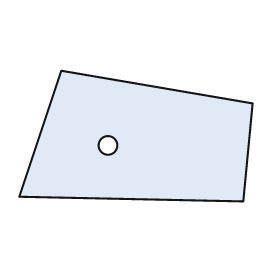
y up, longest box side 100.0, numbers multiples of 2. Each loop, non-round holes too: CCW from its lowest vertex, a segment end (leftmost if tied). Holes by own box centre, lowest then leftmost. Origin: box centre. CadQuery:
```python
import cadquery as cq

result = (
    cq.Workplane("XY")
    .moveTo(46.0, -28.0)
    .lineTo(50.0, 14.0)
    .lineTo(-32.0, 28.0)
    .lineTo(-50.0, -26.0)
    .close()
    .moveTo(-12.0, -4.0)
    .circle(4.0)
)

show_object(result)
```